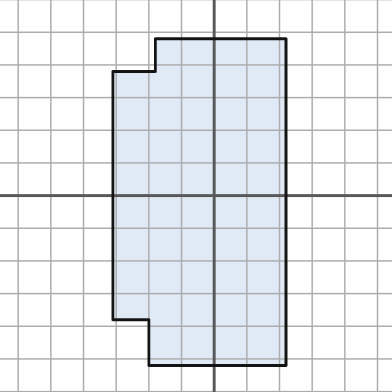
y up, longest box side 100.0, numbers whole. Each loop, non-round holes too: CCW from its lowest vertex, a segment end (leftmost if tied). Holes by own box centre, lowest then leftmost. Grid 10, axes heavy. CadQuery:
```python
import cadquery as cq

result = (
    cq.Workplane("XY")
    .moveTo(-20.0, -52.0)
    .lineTo(22.0, -52.0)
    .lineTo(22.0, 48.0)
    .lineTo(-18.0, 48.0)
    .lineTo(-18.0, 38.0)
    .lineTo(-31.0, 38.0)
    .lineTo(-31.0, -38.0)
    .lineTo(-20.0, -38.0)
    .close()
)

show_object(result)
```